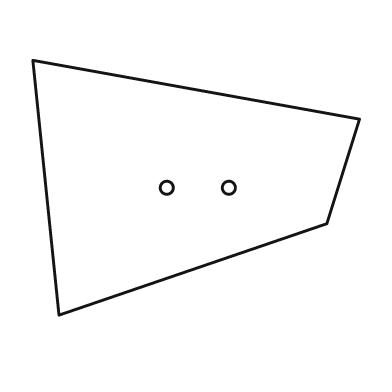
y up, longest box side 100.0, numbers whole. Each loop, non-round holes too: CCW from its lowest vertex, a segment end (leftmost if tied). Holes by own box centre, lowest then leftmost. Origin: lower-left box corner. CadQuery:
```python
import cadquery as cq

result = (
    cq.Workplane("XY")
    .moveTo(8.0, 0.0)
    .lineTo(90.0, 28.0)
    .lineTo(100.0, 60.0)
    .lineTo(0.0, 78.0)
    .close()
    .moveTo(41.0, 39.0)
    .circle(2.0)
    .moveTo(60.0, 39.0)
    .circle(2.0)
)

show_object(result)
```